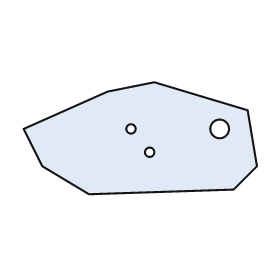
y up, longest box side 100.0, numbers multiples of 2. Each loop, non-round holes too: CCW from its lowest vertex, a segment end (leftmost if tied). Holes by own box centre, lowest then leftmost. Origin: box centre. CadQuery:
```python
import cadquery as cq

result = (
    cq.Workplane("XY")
    .moveTo(-22.0, -24.0)
    .lineTo(40.0, -22.0)
    .lineTo(50.0, -12.0)
    .lineTo(46.0, 12.0)
    .lineTo(6.0, 24.0)
    .lineTo(-14.0, 20.0)
    .lineTo(-50.0, 4.0)
    .lineTo(-42.0, -12.0)
    .close()
    .moveTo(4.0, -6.0)
    .circle(2.0)
    .moveTo(-4.0, 4.0)
    .circle(2.0)
    .moveTo(34.0, 4.0)
    .circle(4.0)
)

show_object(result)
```